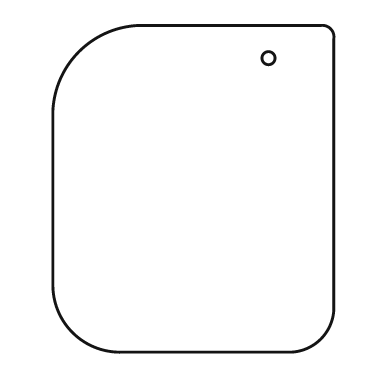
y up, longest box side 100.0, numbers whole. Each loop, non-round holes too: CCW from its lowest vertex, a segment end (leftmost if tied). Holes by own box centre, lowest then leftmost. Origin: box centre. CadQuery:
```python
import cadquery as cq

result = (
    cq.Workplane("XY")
    .moveTo(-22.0, -50.0)
    .lineTo(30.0, -50.0)
    .threePointArc((39.0, -46.0), (43.0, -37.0))
    .lineTo(43.0, 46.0)
    .threePointArc((42.0, 49.0), (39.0, 50.0))
    .lineTo(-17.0, 50.0)
    .threePointArc((-35.0, 42.0), (-43.0, 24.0))
    .lineTo(-43.0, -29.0)
    .threePointArc((-37.0, -44.0), (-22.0, -50.0))
    .close()
    .moveTo(23.0, 40.0)
    .circle(2.0)
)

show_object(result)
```